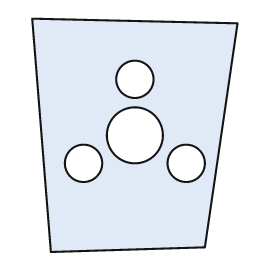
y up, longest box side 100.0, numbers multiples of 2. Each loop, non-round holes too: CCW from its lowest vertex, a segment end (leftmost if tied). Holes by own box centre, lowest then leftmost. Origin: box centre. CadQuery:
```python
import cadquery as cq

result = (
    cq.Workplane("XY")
    .moveTo(-36.0, -50.0)
    .lineTo(30.0, -48.0)
    .lineTo(44.0, 48.0)
    .lineTo(-44.0, 50.0)
    .close()
    .moveTo(-22.0, -12.0)
    .circle(8.0)
    .moveTo(22.0, -12.0)
    .circle(8.0)
    .moveTo(0.0, 0.0)
    .circle(12.0)
    .moveTo(0.0, 24.0)
    .circle(8.0)
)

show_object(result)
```